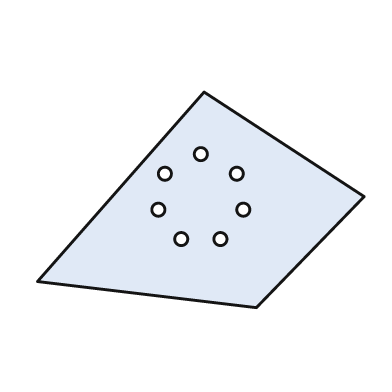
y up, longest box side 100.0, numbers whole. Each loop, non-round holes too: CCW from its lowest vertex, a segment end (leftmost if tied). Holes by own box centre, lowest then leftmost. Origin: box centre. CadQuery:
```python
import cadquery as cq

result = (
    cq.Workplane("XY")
    .moveTo(17.0, -33.0)
    .lineTo(50.0, 1.0)
    .lineTo(1.0, 33.0)
    .lineTo(-50.0, -25.0)
    .close()
    .moveTo(-6.0, -12.0)
    .circle(2.0)
    .moveTo(6.0, -12.0)
    .circle(2.0)
    .moveTo(-13.0, -3.0)
    .circle(2.0)
    .moveTo(13.0, -3.0)
    .circle(2.0)
    .moveTo(-11.0, 8.0)
    .circle(2.0)
    .moveTo(11.0, 8.0)
    .circle(2.0)
    .moveTo(0.0, 14.0)
    .circle(2.0)
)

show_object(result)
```